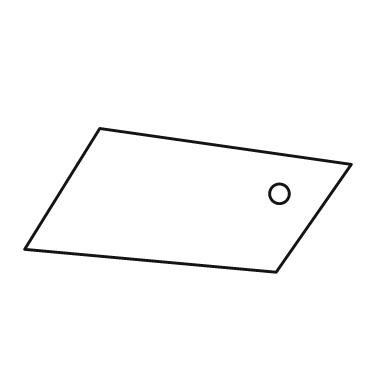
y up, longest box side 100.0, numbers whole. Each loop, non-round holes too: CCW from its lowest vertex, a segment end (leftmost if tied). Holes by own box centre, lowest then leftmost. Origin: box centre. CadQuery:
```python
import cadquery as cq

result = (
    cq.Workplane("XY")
    .moveTo(27.0, -22.0)
    .lineTo(50.0, 11.0)
    .lineTo(-27.0, 22.0)
    .lineTo(-50.0, -15.0)
    .close()
    .moveTo(28.0, 2.0)
    .circle(3.0)
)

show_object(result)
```